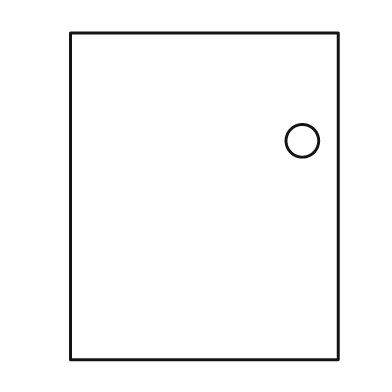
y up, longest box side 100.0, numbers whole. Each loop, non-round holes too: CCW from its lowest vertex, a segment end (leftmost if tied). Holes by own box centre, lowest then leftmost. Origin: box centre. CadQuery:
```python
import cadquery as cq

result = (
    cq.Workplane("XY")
    .moveTo(-41.0, -50.0)
    .lineTo(41.0, -50.0)
    .lineTo(41.0, 50.0)
    .lineTo(-41.0, 50.0)
    .close()
    .moveTo(30.0, 17.0)
    .circle(5.0)
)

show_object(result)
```